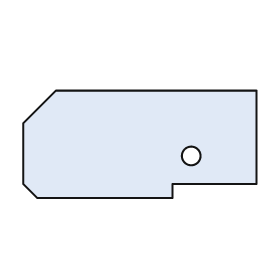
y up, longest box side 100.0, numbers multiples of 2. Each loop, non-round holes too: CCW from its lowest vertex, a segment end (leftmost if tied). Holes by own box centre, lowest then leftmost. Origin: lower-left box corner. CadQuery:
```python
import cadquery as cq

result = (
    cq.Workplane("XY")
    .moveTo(6.0, 0.0)
    .lineTo(64.0, 0.0)
    .lineTo(64.0, 6.0)
    .lineTo(100.0, 6.0)
    .lineTo(100.0, 46.0)
    .lineTo(14.0, 46.0)
    .lineTo(0.0, 32.0)
    .lineTo(0.0, 6.0)
    .close()
    .moveTo(72.0, 18.0)
    .circle(4.0)
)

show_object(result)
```